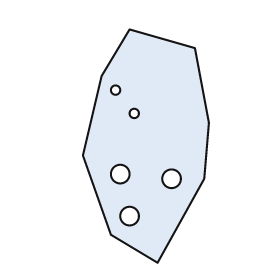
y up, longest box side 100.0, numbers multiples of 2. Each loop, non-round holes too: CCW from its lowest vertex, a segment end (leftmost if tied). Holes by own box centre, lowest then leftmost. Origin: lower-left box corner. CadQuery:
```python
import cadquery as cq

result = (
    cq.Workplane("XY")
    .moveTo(32.0, 0.0)
    .lineTo(52.0, 36.0)
    .lineTo(54.0, 60.0)
    .lineTo(48.0, 92.0)
    .lineTo(20.0, 100.0)
    .lineTo(8.0, 80.0)
    .lineTo(0.0, 46.0)
    .lineTo(12.0, 12.0)
    .close()
    .moveTo(20.0, 20.0)
    .circle(4.0)
    .moveTo(38.0, 36.0)
    .circle(4.0)
    .moveTo(16.0, 38.0)
    .circle(4.0)
    .moveTo(22.0, 64.0)
    .circle(2.0)
    .moveTo(14.0, 74.0)
    .circle(2.0)
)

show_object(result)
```